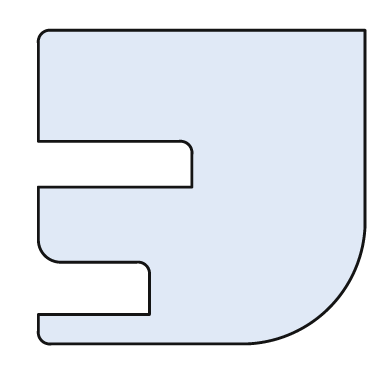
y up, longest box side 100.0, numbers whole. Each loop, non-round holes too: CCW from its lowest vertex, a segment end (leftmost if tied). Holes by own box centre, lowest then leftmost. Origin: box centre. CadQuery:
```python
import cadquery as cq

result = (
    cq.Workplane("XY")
    .moveTo(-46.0, -48.0)
    .lineTo(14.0, -48.0)
    .threePointArc((39.0, -37.0), (50.0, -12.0))
    .lineTo(50.0, 48.0)
    .lineTo(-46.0, 48.0)
    .threePointArc((-49.0, 47.0), (-50.0, 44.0))
    .lineTo(-50.0, 14.0)
    .lineTo(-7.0, 14.0)
    .threePointArc((-4.0, 13.0), (-3.0, 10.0))
    .lineTo(-3.0, 0.0)
    .lineTo(-50.0, 0.0)
    .lineTo(-50.0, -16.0)
    .threePointArc((-48.0, -21.0), (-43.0, -23.0))
    .lineTo(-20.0, -23.0)
    .threePointArc((-17.0, -24.0), (-16.0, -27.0))
    .lineTo(-16.0, -39.0)
    .lineTo(-50.0, -39.0)
    .lineTo(-50.0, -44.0)
    .threePointArc((-49.0, -47.0), (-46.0, -48.0))
    .close()
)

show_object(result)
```